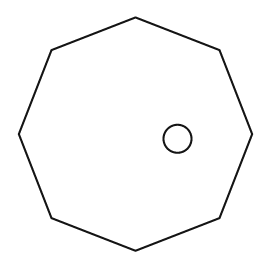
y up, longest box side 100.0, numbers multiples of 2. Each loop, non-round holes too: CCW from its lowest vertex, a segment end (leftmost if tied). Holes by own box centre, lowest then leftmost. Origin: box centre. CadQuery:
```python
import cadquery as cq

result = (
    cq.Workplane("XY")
    .moveTo(0.0, -50.0)
    .lineTo(36.0, -36.0)
    .lineTo(50.0, 0.0)
    .lineTo(36.0, 36.0)
    .lineTo(0.0, 50.0)
    .lineTo(-36.0, 36.0)
    .lineTo(-50.0, 0.0)
    .lineTo(-36.0, -36.0)
    .close()
    .moveTo(18.0, -2.0)
    .circle(6.0)
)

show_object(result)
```